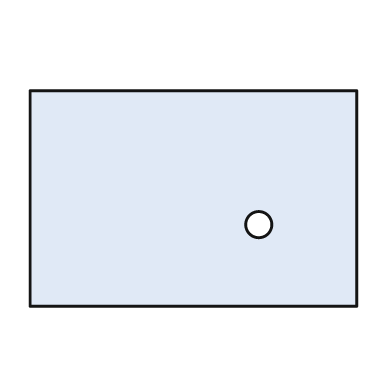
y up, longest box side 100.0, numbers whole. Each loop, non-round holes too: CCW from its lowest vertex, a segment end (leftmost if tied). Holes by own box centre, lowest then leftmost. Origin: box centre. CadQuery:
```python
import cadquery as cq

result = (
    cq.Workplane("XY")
    .moveTo(-50.0, -33.0)
    .lineTo(50.0, -33.0)
    .lineTo(50.0, 33.0)
    .lineTo(-50.0, 33.0)
    .close()
    .moveTo(20.0, -8.0)
    .circle(4.0)
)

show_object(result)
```